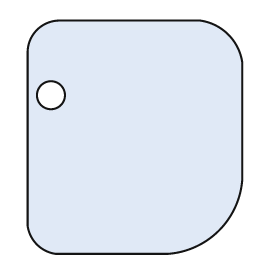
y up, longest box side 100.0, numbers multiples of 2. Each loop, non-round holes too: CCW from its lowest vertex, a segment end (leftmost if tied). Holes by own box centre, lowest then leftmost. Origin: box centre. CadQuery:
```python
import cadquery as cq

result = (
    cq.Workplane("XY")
    .moveTo(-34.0, -50.0)
    .lineTo(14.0, -50.0)
    .threePointArc((36.0, -40.0), (46.0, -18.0))
    .lineTo(46.0, 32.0)
    .threePointArc((40.0, 44.0), (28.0, 50.0))
    .lineTo(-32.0, 50.0)
    .threePointArc((-42.0, 46.0), (-46.0, 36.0))
    .lineTo(-46.0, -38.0)
    .threePointArc((-42.0, -46.0), (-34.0, -50.0))
    .close()
    .moveTo(-36.0, 18.0)
    .circle(6.0)
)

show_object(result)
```